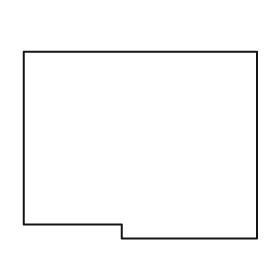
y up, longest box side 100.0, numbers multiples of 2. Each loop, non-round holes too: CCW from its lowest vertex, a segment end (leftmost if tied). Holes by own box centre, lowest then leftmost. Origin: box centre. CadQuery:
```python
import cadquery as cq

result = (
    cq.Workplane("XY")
    .moveTo(-8.0, -40.0)
    .lineTo(50.0, -40.0)
    .lineTo(50.0, 40.0)
    .lineTo(-50.0, 40.0)
    .lineTo(-50.0, -34.0)
    .lineTo(-8.0, -34.0)
    .close()
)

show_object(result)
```